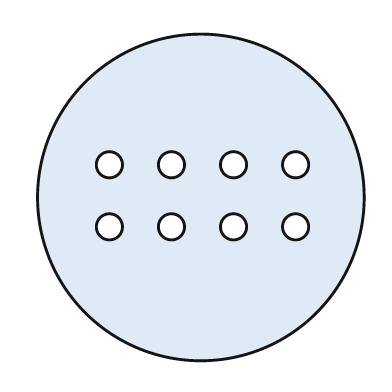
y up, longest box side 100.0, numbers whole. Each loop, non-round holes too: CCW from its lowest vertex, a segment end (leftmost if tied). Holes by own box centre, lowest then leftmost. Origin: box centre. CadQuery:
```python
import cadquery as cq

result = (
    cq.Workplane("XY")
    .moveTo(0.0, 0.0)
    .circle(50.0)
    .moveTo(-28.0, -9.0)
    .circle(4.0)
    .moveTo(-9.0, -9.0)
    .circle(4.0)
    .moveTo(10.0, -9.0)
    .circle(4.0)
    .moveTo(29.0, -9.0)
    .circle(4.0)
    .moveTo(-28.0, 10.0)
    .circle(4.0)
    .moveTo(-9.0, 10.0)
    .circle(4.0)
    .moveTo(10.0, 10.0)
    .circle(4.0)
    .moveTo(29.0, 10.0)
    .circle(4.0)
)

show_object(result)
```